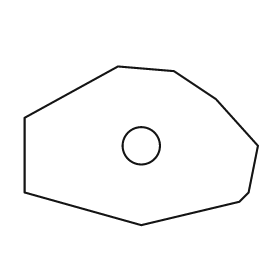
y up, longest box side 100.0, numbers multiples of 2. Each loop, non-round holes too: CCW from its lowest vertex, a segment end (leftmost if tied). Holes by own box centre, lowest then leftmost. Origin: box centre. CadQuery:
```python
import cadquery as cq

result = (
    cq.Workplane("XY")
    .moveTo(0.0, -34.0)
    .lineTo(42.0, -24.0)
    .lineTo(46.0, -20.0)
    .lineTo(50.0, 0.0)
    .lineTo(32.0, 20.0)
    .lineTo(14.0, 32.0)
    .lineTo(-10.0, 34.0)
    .lineTo(-50.0, 12.0)
    .lineTo(-50.0, -20.0)
    .close()
    .moveTo(0.0, 0.0)
    .circle(8.0)
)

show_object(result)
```